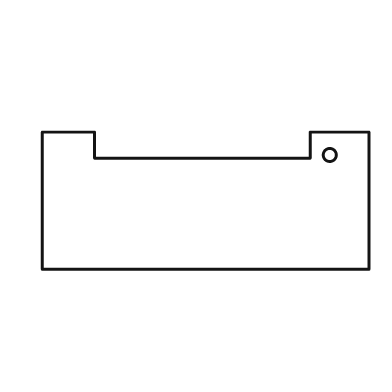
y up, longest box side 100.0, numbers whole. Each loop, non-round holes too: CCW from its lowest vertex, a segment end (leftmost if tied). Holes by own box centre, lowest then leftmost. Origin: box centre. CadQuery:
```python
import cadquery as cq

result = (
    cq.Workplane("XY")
    .moveTo(-50.0, -21.0)
    .lineTo(50.0, -21.0)
    .lineTo(50.0, 21.0)
    .lineTo(32.0, 21.0)
    .lineTo(32.0, 13.0)
    .lineTo(-34.0, 13.0)
    .lineTo(-34.0, 21.0)
    .lineTo(-50.0, 21.0)
    .close()
    .moveTo(38.0, 14.0)
    .circle(2.0)
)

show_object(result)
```